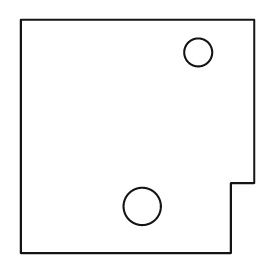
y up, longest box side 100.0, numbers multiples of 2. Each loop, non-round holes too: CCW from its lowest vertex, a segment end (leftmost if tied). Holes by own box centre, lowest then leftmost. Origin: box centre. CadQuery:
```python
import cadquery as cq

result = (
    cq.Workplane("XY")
    .moveTo(-50.0, -50.0)
    .lineTo(40.0, -50.0)
    .lineTo(40.0, -20.0)
    .lineTo(50.0, -20.0)
    .lineTo(50.0, 50.0)
    .lineTo(-50.0, 50.0)
    .close()
    .moveTo(2.0, -30.0)
    .circle(8.0)
    .moveTo(26.0, 36.0)
    .circle(6.0)
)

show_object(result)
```